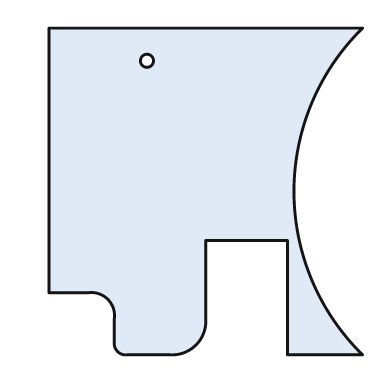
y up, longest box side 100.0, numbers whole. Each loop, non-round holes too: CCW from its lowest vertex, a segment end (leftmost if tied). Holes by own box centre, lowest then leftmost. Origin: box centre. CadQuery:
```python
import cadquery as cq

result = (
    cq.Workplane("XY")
    .moveTo(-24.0, -50.0)
    .lineTo(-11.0, -50.0)
    .threePointArc((-3.0, -47.0), (0.0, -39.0))
    .lineTo(0.0, -15.0)
    .lineTo(25.0, -15.0)
    .lineTo(25.0, -50.0)
    .lineTo(48.0, -50.0)
    .threePointArc((27.0, 0.0), (48.0, 50.0))
    .lineTo(-48.0, 50.0)
    .lineTo(-48.0, -31.0)
    .lineTo(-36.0, -31.0)
    .threePointArc((-30.0, -33.0), (-28.0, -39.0))
    .lineTo(-28.0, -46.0)
    .threePointArc((-27.0, -49.0), (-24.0, -50.0))
    .close()
    .moveTo(-18.0, 40.0)
    .circle(2.0)
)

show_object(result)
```